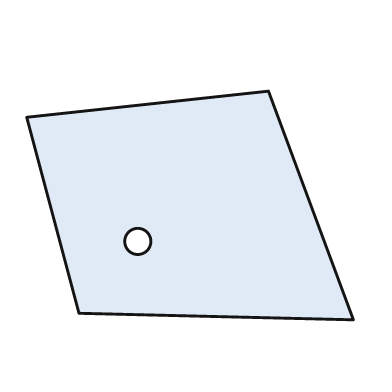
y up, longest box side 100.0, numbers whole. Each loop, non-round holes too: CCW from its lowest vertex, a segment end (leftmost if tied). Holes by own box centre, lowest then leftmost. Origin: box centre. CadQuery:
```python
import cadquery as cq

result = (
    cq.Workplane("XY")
    .moveTo(50.0, -35.0)
    .lineTo(24.0, 35.0)
    .lineTo(-50.0, 27.0)
    .lineTo(-34.0, -33.0)
    .close()
    .moveTo(-16.0, -11.0)
    .circle(4.0)
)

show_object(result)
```